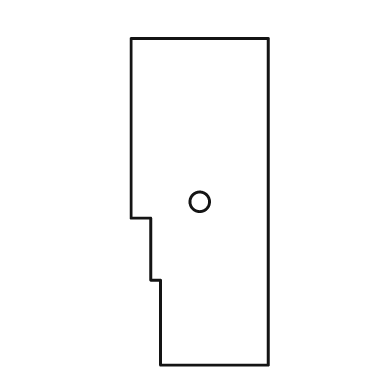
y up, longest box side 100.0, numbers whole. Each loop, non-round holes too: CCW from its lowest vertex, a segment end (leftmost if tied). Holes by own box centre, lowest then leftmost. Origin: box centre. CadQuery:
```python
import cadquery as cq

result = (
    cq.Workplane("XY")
    .moveTo(-12.0, -50.0)
    .lineTo(21.0, -50.0)
    .lineTo(21.0, 50.0)
    .lineTo(-21.0, 50.0)
    .lineTo(-21.0, -5.0)
    .lineTo(-15.0, -5.0)
    .lineTo(-15.0, -24.0)
    .lineTo(-12.0, -24.0)
    .close()
    .moveTo(0.0, 0.0)
    .circle(3.0)
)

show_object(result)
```